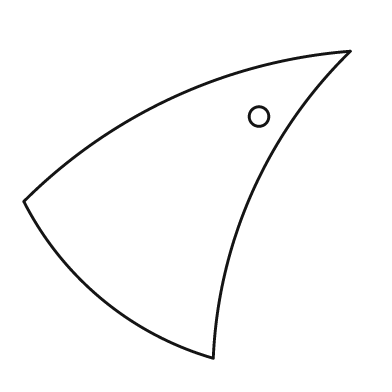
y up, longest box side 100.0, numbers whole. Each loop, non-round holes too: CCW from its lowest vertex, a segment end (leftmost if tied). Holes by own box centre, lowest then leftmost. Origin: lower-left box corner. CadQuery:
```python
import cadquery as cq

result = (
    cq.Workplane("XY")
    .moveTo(58.0, 0.0)
    .threePointArc((70.0, 51.0), (100.0, 94.0))
    .threePointArc((46.0, 80.0), (0.0, 48.0))
    .threePointArc((24.0, 18.0), (58.0, 0.0))
    .close()
    .moveTo(72.0, 74.0)
    .circle(3.0)
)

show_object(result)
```